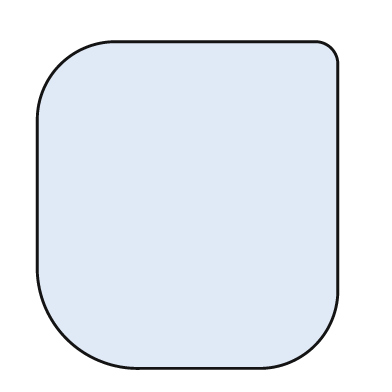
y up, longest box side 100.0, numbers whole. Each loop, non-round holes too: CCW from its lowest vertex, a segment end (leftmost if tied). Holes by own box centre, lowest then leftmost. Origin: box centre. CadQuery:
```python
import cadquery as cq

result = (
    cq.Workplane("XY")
    .moveTo(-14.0, -50.0)
    .lineTo(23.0, -50.0)
    .threePointArc((39.0, -43.0), (46.0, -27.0))
    .lineTo(46.0, 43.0)
    .threePointArc((44.0, 48.0), (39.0, 50.0))
    .lineTo(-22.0, 50.0)
    .threePointArc((-39.0, 43.0), (-46.0, 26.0))
    .lineTo(-46.0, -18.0)
    .threePointArc((-37.0, -41.0), (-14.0, -50.0))
    .close()
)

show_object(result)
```